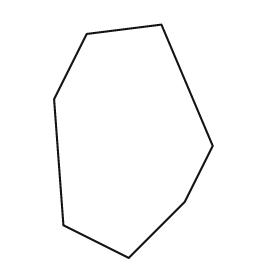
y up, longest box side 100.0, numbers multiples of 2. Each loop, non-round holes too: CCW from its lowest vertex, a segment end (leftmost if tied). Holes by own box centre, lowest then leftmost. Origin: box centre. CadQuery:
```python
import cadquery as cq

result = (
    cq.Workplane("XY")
    .moveTo(-2.0, -50.0)
    .lineTo(22.0, -26.0)
    .lineTo(34.0, -2.0)
    .lineTo(12.0, 50.0)
    .lineTo(-20.0, 46.0)
    .lineTo(-34.0, 18.0)
    .lineTo(-30.0, -36.0)
    .close()
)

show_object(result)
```